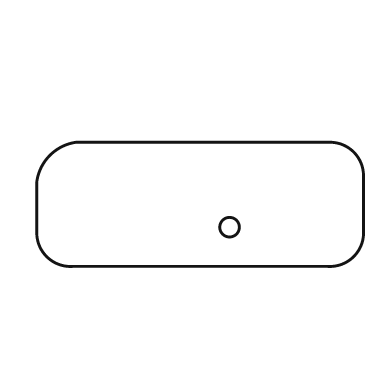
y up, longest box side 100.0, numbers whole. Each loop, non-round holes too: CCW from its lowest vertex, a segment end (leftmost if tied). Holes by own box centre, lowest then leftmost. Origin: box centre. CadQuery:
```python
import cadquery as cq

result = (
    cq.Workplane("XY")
    .moveTo(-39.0, -19.0)
    .lineTo(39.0, -19.0)
    .threePointArc((47.0, -16.0), (50.0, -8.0))
    .lineTo(50.0, 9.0)
    .threePointArc((47.0, 16.0), (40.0, 19.0))
    .lineTo(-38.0, 19.0)
    .threePointArc((-46.0, 15.0), (-50.0, 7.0))
    .lineTo(-50.0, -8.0)
    .threePointArc((-47.0, -16.0), (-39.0, -19.0))
    .close()
    .moveTo(9.0, -7.0)
    .circle(3.0)
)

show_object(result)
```